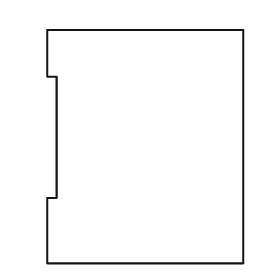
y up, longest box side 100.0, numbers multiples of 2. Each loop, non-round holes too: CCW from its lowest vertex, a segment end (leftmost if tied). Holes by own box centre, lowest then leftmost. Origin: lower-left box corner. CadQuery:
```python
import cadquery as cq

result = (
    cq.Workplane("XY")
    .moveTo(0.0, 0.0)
    .lineTo(84.0, 0.0)
    .lineTo(84.0, 100.0)
    .lineTo(0.0, 100.0)
    .lineTo(0.0, 80.0)
    .lineTo(4.0, 80.0)
    .lineTo(4.0, 28.0)
    .lineTo(0.0, 28.0)
    .close()
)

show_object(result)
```